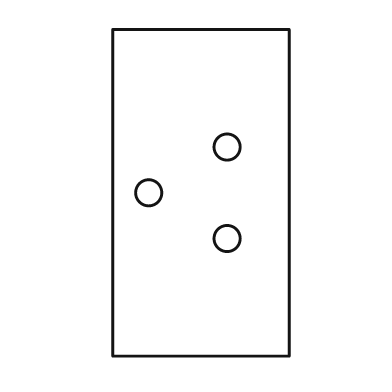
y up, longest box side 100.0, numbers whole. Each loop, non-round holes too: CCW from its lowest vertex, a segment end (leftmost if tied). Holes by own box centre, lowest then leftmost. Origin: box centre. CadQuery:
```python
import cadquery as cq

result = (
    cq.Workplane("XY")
    .moveTo(-27.0, -50.0)
    .lineTo(27.0, -50.0)
    .lineTo(27.0, 50.0)
    .lineTo(-27.0, 50.0)
    .close()
    .moveTo(8.0, -14.0)
    .circle(4.0)
    .moveTo(-16.0, 0.0)
    .circle(4.0)
    .moveTo(8.0, 14.0)
    .circle(4.0)
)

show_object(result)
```